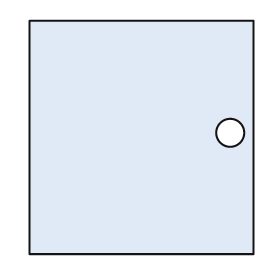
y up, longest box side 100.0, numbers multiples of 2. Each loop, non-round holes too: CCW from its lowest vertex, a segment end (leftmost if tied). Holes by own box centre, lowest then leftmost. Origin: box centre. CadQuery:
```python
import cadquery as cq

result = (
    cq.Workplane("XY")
    .moveTo(-48.0, -50.0)
    .lineTo(48.0, -50.0)
    .lineTo(48.0, 50.0)
    .lineTo(-48.0, 50.0)
    .close()
    .moveTo(38.0, 2.0)
    .circle(6.0)
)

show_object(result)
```